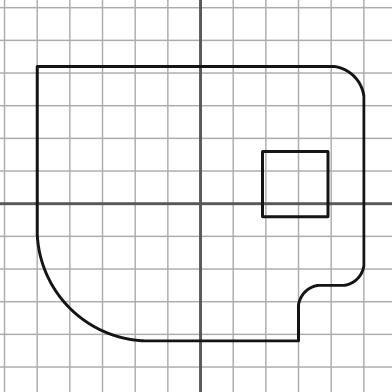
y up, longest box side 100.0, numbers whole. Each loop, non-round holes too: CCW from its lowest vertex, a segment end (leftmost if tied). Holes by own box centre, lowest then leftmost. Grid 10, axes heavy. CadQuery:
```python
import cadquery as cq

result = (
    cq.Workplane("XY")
    .moveTo(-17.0, -42.0)
    .lineTo(30.0, -42.0)
    .lineTo(30.0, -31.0)
    .threePointArc((32.0, -27.0), (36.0, -25.0))
    .lineTo(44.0, -25.0)
    .threePointArc((48.0, -23.0), (50.0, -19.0))
    .lineTo(50.0, 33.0)
    .threePointArc((47.0, 39.0), (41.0, 42.0))
    .lineTo(-50.0, 42.0)
    .lineTo(-50.0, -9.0)
    .threePointArc((-40.0, -32.0), (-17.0, -42.0))
    .close()
    .moveTo(19.0, -4.0)
    .lineTo(39.0, -4.0)
    .lineTo(39.0, 16.0)
    .lineTo(19.0, 16.0)
    .close()
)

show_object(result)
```